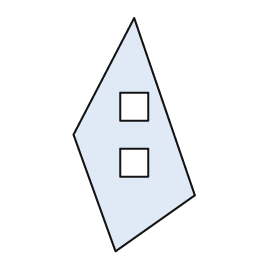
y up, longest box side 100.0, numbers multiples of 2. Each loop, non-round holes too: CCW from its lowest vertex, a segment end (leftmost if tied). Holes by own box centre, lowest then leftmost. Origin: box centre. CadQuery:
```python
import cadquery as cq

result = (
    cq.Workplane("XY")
    .moveTo(-8.0, -50.0)
    .lineTo(26.0, -26.0)
    .lineTo(0.0, 50.0)
    .lineTo(-26.0, 0.0)
    .close()
    .moveTo(-6.0, -18.0)
    .lineTo(6.0, -18.0)
    .lineTo(6.0, -6.0)
    .lineTo(-6.0, -6.0)
    .close()
    .moveTo(-6.0, 6.0)
    .lineTo(6.0, 6.0)
    .lineTo(6.0, 18.0)
    .lineTo(-6.0, 18.0)
    .close()
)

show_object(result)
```